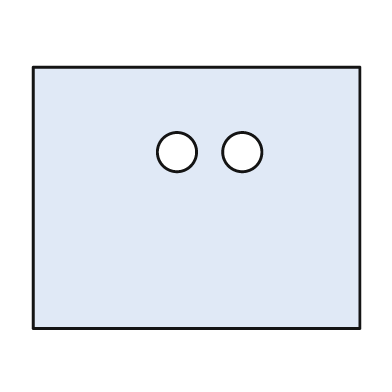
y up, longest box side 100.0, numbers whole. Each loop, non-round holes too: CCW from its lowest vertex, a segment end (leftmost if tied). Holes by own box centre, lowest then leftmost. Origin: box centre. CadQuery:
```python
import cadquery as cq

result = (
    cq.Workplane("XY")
    .moveTo(-50.0, -40.0)
    .lineTo(50.0, -40.0)
    .lineTo(50.0, 40.0)
    .lineTo(-50.0, 40.0)
    .close()
    .moveTo(-6.0, 14.0)
    .circle(6.0)
    .moveTo(14.0, 14.0)
    .circle(6.0)
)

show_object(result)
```